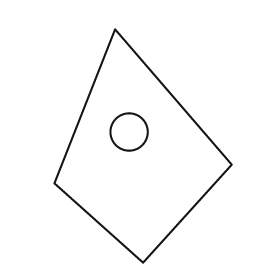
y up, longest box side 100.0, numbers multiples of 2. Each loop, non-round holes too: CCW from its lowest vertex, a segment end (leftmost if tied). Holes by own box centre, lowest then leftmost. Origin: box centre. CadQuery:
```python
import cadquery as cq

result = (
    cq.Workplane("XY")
    .moveTo(0.0, -50.0)
    .lineTo(38.0, -8.0)
    .lineTo(-12.0, 50.0)
    .lineTo(-38.0, -16.0)
    .close()
    .moveTo(-6.0, 6.0)
    .circle(8.0)
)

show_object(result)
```